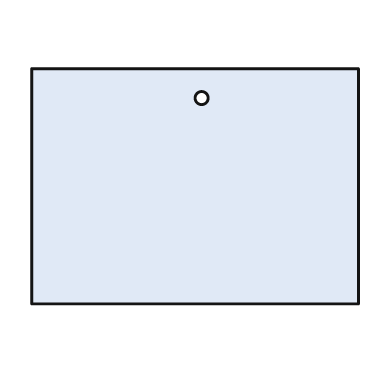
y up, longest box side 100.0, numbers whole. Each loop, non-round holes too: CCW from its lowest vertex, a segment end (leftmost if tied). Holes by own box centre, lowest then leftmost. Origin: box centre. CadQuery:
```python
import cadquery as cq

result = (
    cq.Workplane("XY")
    .moveTo(-50.0, -36.0)
    .lineTo(50.0, -36.0)
    .lineTo(50.0, 36.0)
    .lineTo(-50.0, 36.0)
    .close()
    .moveTo(2.0, 27.0)
    .circle(2.0)
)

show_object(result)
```